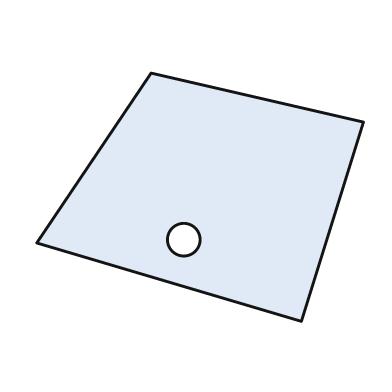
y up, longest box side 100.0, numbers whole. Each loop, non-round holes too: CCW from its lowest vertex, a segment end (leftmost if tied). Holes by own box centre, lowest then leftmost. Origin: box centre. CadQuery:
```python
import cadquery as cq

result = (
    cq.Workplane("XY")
    .moveTo(31.0, -38.0)
    .lineTo(50.0, 23.0)
    .lineTo(-15.0, 38.0)
    .lineTo(-50.0, -14.0)
    .close()
    .moveTo(-5.0, -13.0)
    .circle(5.0)
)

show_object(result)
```